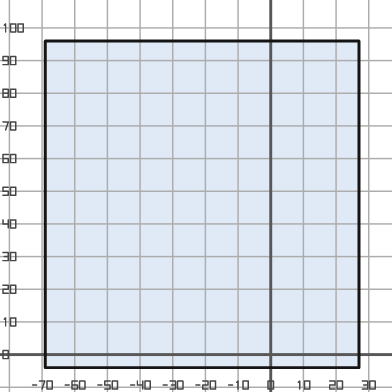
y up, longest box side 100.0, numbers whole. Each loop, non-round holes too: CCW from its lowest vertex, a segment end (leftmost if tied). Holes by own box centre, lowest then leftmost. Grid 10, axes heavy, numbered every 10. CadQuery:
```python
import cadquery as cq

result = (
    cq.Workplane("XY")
    .moveTo(-69.0, -4.0)
    .lineTo(27.0, -4.0)
    .lineTo(27.0, 96.0)
    .lineTo(-69.0, 96.0)
    .close()
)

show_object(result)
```